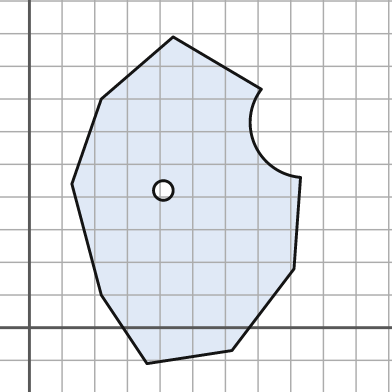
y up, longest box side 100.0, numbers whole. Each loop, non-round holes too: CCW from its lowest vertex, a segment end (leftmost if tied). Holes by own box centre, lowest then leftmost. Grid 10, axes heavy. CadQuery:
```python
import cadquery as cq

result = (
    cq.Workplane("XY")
    .moveTo(36.0, -11.0)
    .lineTo(62.0, -7.0)
    .lineTo(81.0, 18.0)
    .lineTo(83.0, 46.0)
    .threePointArc((69.0, 56.0), (71.0, 73.0))
    .lineTo(44.0, 89.0)
    .lineTo(22.0, 70.0)
    .lineTo(13.0, 44.0)
    .lineTo(22.0, 10.0)
    .close()
    .moveTo(41.0, 42.0)
    .circle(3.0)
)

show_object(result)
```